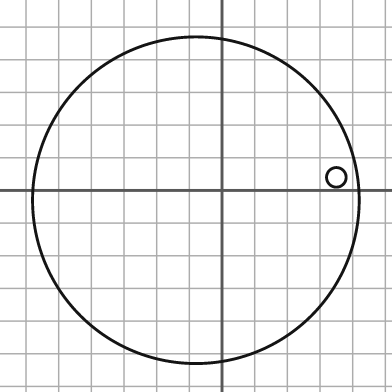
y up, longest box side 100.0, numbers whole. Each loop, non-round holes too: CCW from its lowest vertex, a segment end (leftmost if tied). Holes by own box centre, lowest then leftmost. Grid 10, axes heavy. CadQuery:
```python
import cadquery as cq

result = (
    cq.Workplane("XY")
    .moveTo(-8.0, -3.0)
    .circle(50.0)
    .moveTo(35.0, 4.0)
    .circle(3.0)
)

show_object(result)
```